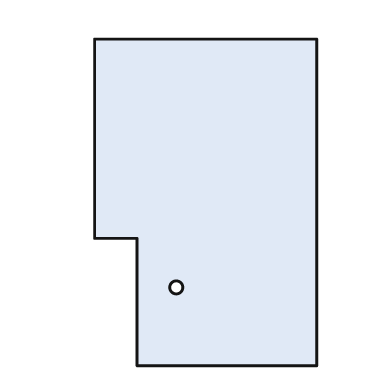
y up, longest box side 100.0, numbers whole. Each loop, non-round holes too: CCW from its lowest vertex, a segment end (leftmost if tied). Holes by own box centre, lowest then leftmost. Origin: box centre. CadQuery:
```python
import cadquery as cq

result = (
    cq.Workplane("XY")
    .moveTo(-21.0, -50.0)
    .lineTo(34.0, -50.0)
    .lineTo(34.0, 50.0)
    .lineTo(-34.0, 50.0)
    .lineTo(-34.0, -11.0)
    .lineTo(-21.0, -11.0)
    .close()
    .moveTo(-9.0, -26.0)
    .circle(2.0)
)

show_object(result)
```